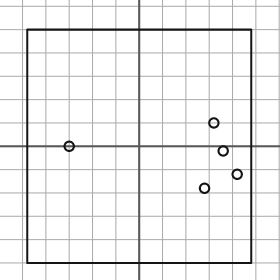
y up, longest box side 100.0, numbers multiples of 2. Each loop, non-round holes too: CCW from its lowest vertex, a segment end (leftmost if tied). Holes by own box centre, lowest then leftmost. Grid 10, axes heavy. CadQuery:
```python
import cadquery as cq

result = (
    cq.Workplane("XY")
    .moveTo(-48.0, -50.0)
    .lineTo(48.0, -50.0)
    .lineTo(48.0, 50.0)
    .lineTo(-48.0, 50.0)
    .close()
    .moveTo(28.0, -18.0)
    .circle(2.0)
    .moveTo(42.0, -12.0)
    .circle(2.0)
    .moveTo(36.0, -2.0)
    .circle(2.0)
    .moveTo(-30.0, 0.0)
    .circle(2.0)
    .moveTo(32.0, 10.0)
    .circle(2.0)
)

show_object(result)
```